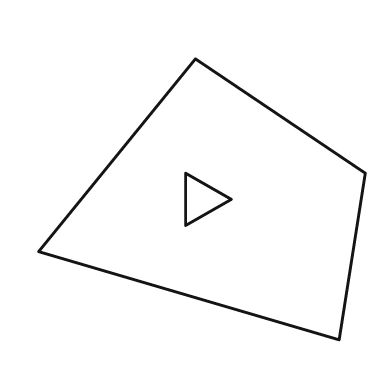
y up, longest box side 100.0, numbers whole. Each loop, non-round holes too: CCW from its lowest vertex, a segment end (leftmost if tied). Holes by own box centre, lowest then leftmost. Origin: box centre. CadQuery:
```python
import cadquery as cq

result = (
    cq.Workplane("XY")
    .moveTo(42.0, -43.0)
    .lineTo(50.0, 8.0)
    .lineTo(-2.0, 43.0)
    .lineTo(-50.0, -16.0)
    .close()
    .moveTo(-5.0, -8.0)
    .lineTo(9.0, 0.0)
    .lineTo(-5.0, 8.0)
    .close()
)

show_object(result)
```